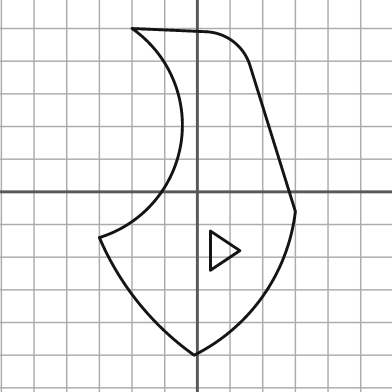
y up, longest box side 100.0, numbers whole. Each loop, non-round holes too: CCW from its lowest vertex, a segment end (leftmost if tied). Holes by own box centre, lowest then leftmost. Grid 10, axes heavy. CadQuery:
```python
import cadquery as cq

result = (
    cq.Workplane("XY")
    .moveTo(-1.0, -50.0)
    .threePointArc((20.0, -32.0), (30.0, -6.0))
    .lineTo(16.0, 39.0)
    .threePointArc((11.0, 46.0), (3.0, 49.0))
    .lineTo(-20.0, 50.0)
    .threePointArc((-5.0, 15.0), (-30.0, -14.0))
    .threePointArc((-18.0, -34.0), (-1.0, -50.0))
    .close()
    .moveTo(4.0, -24.0)
    .lineTo(13.0, -18.0)
    .lineTo(4.0, -12.0)
    .close()
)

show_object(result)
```